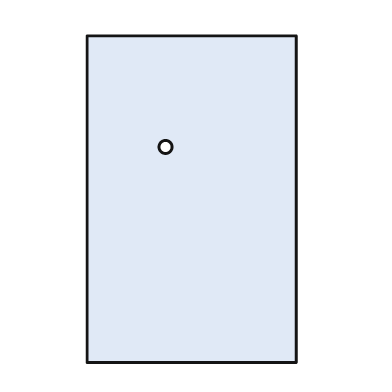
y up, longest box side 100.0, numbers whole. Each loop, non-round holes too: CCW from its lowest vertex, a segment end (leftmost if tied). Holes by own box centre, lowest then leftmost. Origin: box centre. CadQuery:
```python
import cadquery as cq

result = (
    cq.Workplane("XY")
    .moveTo(-32.0, -50.0)
    .lineTo(32.0, -50.0)
    .lineTo(32.0, 50.0)
    .lineTo(-32.0, 50.0)
    .close()
    .moveTo(-8.0, 16.0)
    .circle(2.0)
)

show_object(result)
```